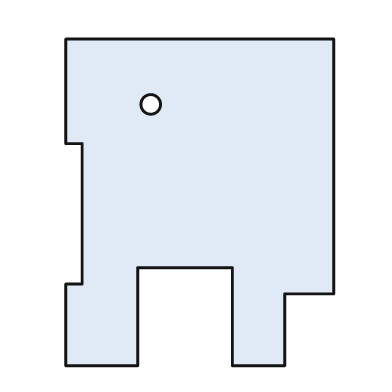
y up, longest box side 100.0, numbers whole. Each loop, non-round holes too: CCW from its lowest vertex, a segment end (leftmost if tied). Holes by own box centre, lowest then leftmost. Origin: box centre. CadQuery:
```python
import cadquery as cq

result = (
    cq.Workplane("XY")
    .moveTo(-41.0, -50.0)
    .lineTo(-19.0, -50.0)
    .lineTo(-19.0, -20.0)
    .lineTo(10.0, -20.0)
    .lineTo(10.0, -50.0)
    .lineTo(26.0, -50.0)
    .lineTo(26.0, -28.0)
    .lineTo(41.0, -28.0)
    .lineTo(41.0, 50.0)
    .lineTo(-41.0, 50.0)
    .lineTo(-41.0, 18.0)
    .lineTo(-36.0, 18.0)
    .lineTo(-36.0, -25.0)
    .lineTo(-41.0, -25.0)
    .close()
    .moveTo(-15.0, 30.0)
    .circle(3.0)
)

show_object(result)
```